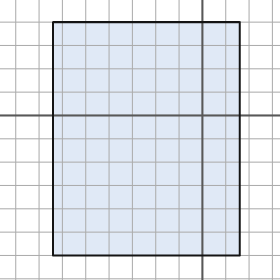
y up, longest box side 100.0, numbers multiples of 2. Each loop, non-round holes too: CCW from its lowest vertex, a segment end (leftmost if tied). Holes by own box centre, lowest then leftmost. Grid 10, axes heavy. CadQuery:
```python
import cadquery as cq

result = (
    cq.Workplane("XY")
    .moveTo(-64.0, -60.0)
    .lineTo(16.0, -60.0)
    .lineTo(16.0, 40.0)
    .lineTo(-64.0, 40.0)
    .close()
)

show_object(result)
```